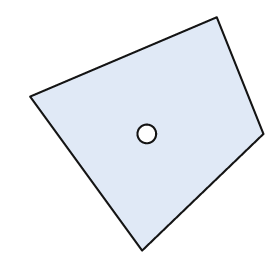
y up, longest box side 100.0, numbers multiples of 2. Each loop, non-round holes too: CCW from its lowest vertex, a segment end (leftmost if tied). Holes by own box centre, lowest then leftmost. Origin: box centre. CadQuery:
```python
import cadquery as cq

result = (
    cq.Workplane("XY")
    .moveTo(-2.0, -50.0)
    .lineTo(50.0, 0.0)
    .lineTo(30.0, 50.0)
    .lineTo(-50.0, 16.0)
    .close()
    .moveTo(0.0, 0.0)
    .circle(4.0)
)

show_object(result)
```